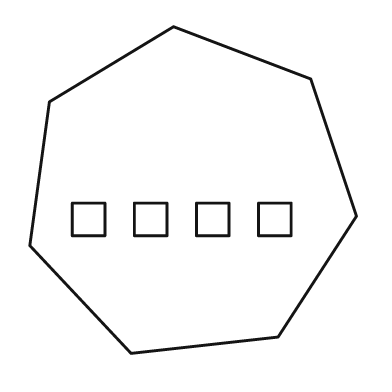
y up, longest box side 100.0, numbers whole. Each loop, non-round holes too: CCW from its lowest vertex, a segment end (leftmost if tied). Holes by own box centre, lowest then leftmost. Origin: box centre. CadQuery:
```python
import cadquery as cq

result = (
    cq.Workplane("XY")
    .moveTo(-19.0, -50.0)
    .lineTo(26.0, -45.0)
    .lineTo(50.0, -8.0)
    .lineTo(36.0, 34.0)
    .lineTo(-6.0, 50.0)
    .lineTo(-44.0, 27.0)
    .lineTo(-50.0, -17.0)
    .close()
    .moveTo(-37.0, -14.0)
    .lineTo(-27.0, -14.0)
    .lineTo(-27.0, -4.0)
    .lineTo(-37.0, -4.0)
    .close()
    .moveTo(-18.0, -14.0)
    .lineTo(-8.0, -14.0)
    .lineTo(-8.0, -4.0)
    .lineTo(-18.0, -4.0)
    .close()
    .moveTo(1.0, -14.0)
    .lineTo(11.0, -14.0)
    .lineTo(11.0, -4.0)
    .lineTo(1.0, -4.0)
    .close()
    .moveTo(20.0, -14.0)
    .lineTo(30.0, -14.0)
    .lineTo(30.0, -4.0)
    .lineTo(20.0, -4.0)
    .close()
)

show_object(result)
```